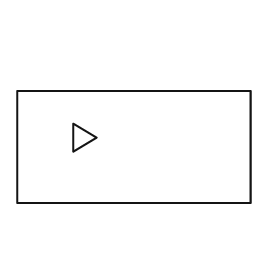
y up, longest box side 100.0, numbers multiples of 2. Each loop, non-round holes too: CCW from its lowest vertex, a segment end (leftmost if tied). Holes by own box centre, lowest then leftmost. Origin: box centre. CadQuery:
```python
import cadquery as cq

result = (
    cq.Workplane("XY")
    .moveTo(-50.0, -24.0)
    .lineTo(50.0, -24.0)
    .lineTo(50.0, 24.0)
    .lineTo(-50.0, 24.0)
    .close()
    .moveTo(-26.0, -2.0)
    .lineTo(-16.0, 4.0)
    .lineTo(-26.0, 10.0)
    .close()
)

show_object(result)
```